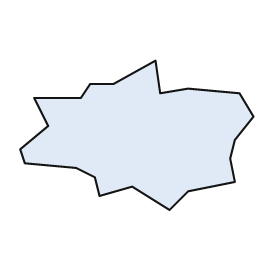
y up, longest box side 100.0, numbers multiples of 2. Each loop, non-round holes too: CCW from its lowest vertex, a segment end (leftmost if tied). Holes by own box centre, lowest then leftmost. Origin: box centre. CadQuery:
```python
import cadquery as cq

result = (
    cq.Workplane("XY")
    .moveTo(14.0, -32.0)
    .lineTo(22.0, -24.0)
    .lineTo(42.0, -20.0)
    .lineTo(40.0, -10.0)
    .lineTo(42.0, -2.0)
    .lineTo(50.0, 8.0)
    .lineTo(44.0, 18.0)
    .lineTo(22.0, 20.0)
    .lineTo(10.0, 18.0)
    .lineTo(8.0, 32.0)
    .lineTo(-10.0, 22.0)
    .lineTo(-20.0, 22.0)
    .lineTo(-24.0, 16.0)
    .lineTo(-44.0, 16.0)
    .lineTo(-38.0, 4.0)
    .lineTo(-50.0, -6.0)
    .lineTo(-48.0, -12.0)
    .lineTo(-26.0, -14.0)
    .lineTo(-18.0, -18.0)
    .lineTo(-16.0, -26.0)
    .lineTo(-2.0, -22.0)
    .close()
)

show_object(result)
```